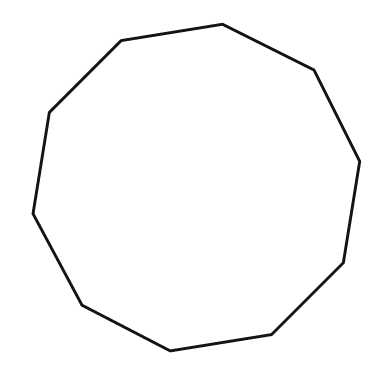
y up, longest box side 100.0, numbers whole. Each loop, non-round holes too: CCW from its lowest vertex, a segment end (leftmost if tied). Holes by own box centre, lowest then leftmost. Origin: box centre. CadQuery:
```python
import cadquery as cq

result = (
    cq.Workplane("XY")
    .moveTo(-8.0, -50.0)
    .lineTo(23.0, -45.0)
    .lineTo(45.0, -23.0)
    .lineTo(50.0, 8.0)
    .lineTo(36.0, 36.0)
    .lineTo(8.0, 50.0)
    .lineTo(-23.0, 45.0)
    .lineTo(-45.0, 23.0)
    .lineTo(-50.0, -8.0)
    .lineTo(-35.0, -36.0)
    .close()
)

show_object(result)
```